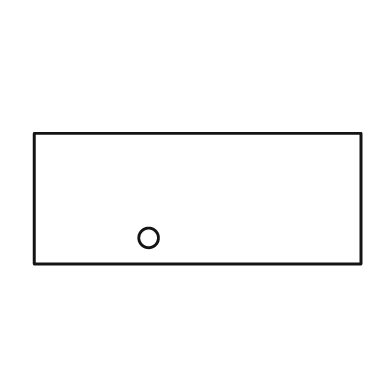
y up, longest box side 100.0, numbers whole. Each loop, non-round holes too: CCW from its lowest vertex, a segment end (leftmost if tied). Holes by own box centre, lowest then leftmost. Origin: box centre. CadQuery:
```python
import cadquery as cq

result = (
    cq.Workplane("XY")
    .moveTo(-50.0, -20.0)
    .lineTo(50.0, -20.0)
    .lineTo(50.0, 20.0)
    .lineTo(-50.0, 20.0)
    .close()
    .moveTo(-15.0, -12.0)
    .circle(3.0)
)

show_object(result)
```